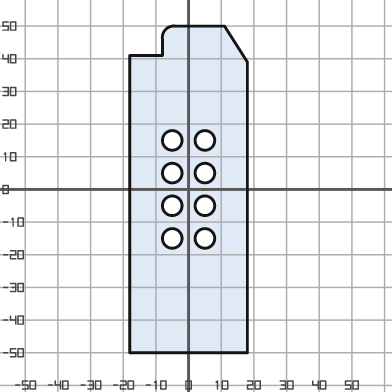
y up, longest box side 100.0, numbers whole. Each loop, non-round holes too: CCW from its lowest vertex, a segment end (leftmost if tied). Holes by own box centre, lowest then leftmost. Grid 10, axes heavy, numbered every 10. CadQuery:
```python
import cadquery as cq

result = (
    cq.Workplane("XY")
    .moveTo(-18.0, -50.0)
    .lineTo(18.0, -50.0)
    .lineTo(18.0, 39.0)
    .lineTo(11.0, 50.0)
    .lineTo(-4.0, 50.0)
    .threePointArc((-7.0, 49.0), (-8.0, 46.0))
    .lineTo(-8.0, 41.0)
    .lineTo(-18.0, 41.0)
    .close()
    .moveTo(-5.0, -15.0)
    .circle(3.0)
    .moveTo(5.0, -15.0)
    .circle(3.0)
    .moveTo(-5.0, -5.0)
    .circle(3.0)
    .moveTo(5.0, -5.0)
    .circle(3.0)
    .moveTo(-5.0, 5.0)
    .circle(3.0)
    .moveTo(5.0, 5.0)
    .circle(3.0)
    .moveTo(-5.0, 15.0)
    .circle(3.0)
    .moveTo(5.0, 15.0)
    .circle(3.0)
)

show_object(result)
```